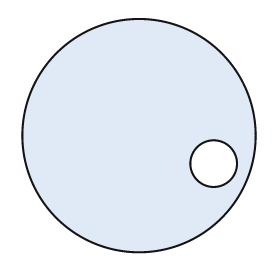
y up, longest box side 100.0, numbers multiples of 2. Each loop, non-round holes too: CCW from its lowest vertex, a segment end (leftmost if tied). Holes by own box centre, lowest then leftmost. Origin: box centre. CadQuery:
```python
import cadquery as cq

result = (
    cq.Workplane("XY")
    .moveTo(0.0, 0.0)
    .circle(50.0)
    .moveTo(32.0, -12.0)
    .circle(10.0)
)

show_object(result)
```